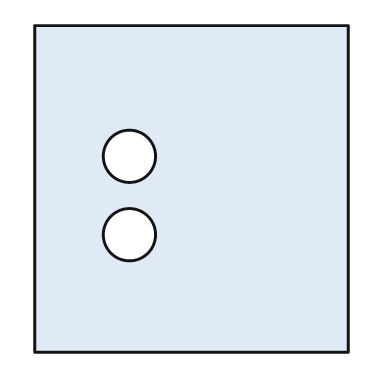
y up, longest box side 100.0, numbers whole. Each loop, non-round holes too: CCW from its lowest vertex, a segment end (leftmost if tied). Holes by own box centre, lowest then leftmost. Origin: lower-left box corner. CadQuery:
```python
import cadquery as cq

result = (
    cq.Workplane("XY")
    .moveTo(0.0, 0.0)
    .lineTo(96.0, 0.0)
    .lineTo(96.0, 100.0)
    .lineTo(0.0, 100.0)
    .close()
    .moveTo(29.0, 36.0)
    .circle(8.0)
    .moveTo(29.0, 60.0)
    .circle(8.0)
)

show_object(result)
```